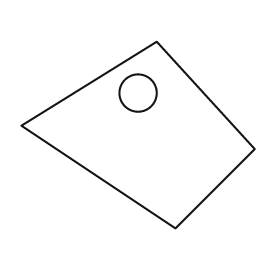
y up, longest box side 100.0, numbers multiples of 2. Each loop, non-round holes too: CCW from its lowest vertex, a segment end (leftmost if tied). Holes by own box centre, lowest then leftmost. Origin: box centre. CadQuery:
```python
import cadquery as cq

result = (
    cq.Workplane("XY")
    .moveTo(16.0, -40.0)
    .lineTo(50.0, -6.0)
    .lineTo(8.0, 40.0)
    .lineTo(-50.0, 4.0)
    .close()
    .moveTo(0.0, 18.0)
    .circle(8.0)
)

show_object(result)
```